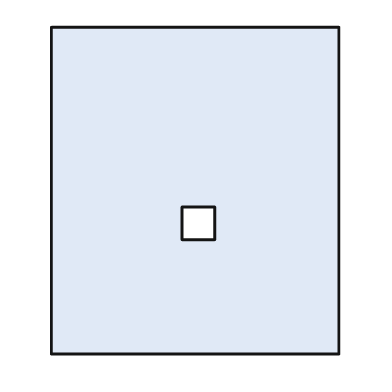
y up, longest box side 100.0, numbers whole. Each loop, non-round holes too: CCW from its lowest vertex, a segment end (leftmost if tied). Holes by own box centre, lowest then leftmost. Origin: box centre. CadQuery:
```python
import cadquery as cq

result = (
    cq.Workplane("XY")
    .moveTo(-44.0, -50.0)
    .lineTo(44.0, -50.0)
    .lineTo(44.0, 50.0)
    .lineTo(-44.0, 50.0)
    .close()
    .moveTo(-4.0, -15.0)
    .lineTo(6.0, -15.0)
    .lineTo(6.0, -5.0)
    .lineTo(-4.0, -5.0)
    .close()
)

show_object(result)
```